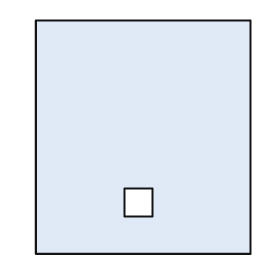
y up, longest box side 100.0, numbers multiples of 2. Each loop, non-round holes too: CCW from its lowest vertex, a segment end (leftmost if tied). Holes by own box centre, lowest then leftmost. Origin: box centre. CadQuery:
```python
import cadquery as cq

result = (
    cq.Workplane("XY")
    .moveTo(-46.0, -50.0)
    .lineTo(46.0, -50.0)
    .lineTo(46.0, 50.0)
    .lineTo(-46.0, 50.0)
    .close()
    .moveTo(-8.0, -34.0)
    .lineTo(4.0, -34.0)
    .lineTo(4.0, -22.0)
    .lineTo(-8.0, -22.0)
    .close()
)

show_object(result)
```